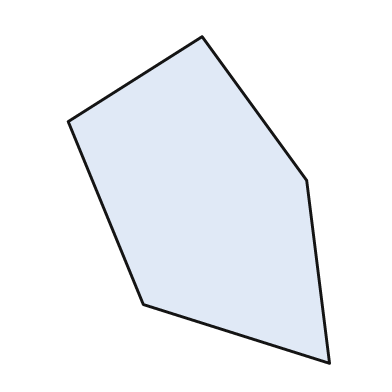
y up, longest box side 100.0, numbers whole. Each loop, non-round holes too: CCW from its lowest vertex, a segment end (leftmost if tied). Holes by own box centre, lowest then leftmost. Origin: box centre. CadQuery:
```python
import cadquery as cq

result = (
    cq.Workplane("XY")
    .moveTo(40.0, -50.0)
    .lineTo(33.0, 6.0)
    .lineTo(1.0, 50.0)
    .lineTo(-40.0, 24.0)
    .lineTo(-17.0, -32.0)
    .close()
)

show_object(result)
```